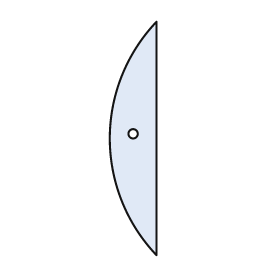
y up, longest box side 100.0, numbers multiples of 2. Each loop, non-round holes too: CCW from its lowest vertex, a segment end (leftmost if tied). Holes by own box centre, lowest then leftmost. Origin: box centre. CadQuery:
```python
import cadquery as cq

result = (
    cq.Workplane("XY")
    .moveTo(10.0, -50.0)
    .lineTo(10.0, 50.0)
    .threePointArc((-10.0, 0.0), (10.0, -50.0))
    .close()
    .moveTo(0.0, 2.0)
    .circle(2.0)
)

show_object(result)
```